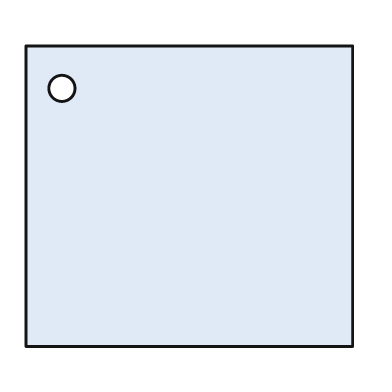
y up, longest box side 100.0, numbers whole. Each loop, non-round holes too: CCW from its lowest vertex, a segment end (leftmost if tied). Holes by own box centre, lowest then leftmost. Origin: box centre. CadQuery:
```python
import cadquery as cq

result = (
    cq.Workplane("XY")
    .moveTo(-50.0, -46.0)
    .lineTo(50.0, -46.0)
    .lineTo(50.0, 46.0)
    .lineTo(-50.0, 46.0)
    .close()
    .moveTo(-39.0, 33.0)
    .circle(4.0)
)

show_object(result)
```